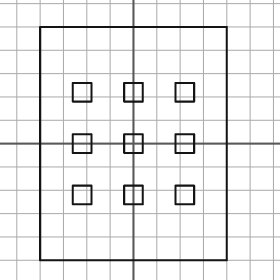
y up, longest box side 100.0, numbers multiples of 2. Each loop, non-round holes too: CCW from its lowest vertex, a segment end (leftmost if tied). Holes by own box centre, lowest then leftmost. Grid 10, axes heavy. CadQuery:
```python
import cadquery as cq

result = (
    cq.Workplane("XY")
    .moveTo(-40.0, -50.0)
    .lineTo(40.0, -50.0)
    .lineTo(40.0, 50.0)
    .lineTo(-40.0, 50.0)
    .close()
    .moveTo(-26.0, -26.0)
    .lineTo(-18.0, -26.0)
    .lineTo(-18.0, -18.0)
    .lineTo(-26.0, -18.0)
    .close()
    .moveTo(-4.0, -26.0)
    .lineTo(4.0, -26.0)
    .lineTo(4.0, -18.0)
    .lineTo(-4.0, -18.0)
    .close()
    .moveTo(18.0, -26.0)
    .lineTo(26.0, -26.0)
    .lineTo(26.0, -18.0)
    .lineTo(18.0, -18.0)
    .close()
    .moveTo(-26.0, -4.0)
    .lineTo(-18.0, -4.0)
    .lineTo(-18.0, 4.0)
    .lineTo(-26.0, 4.0)
    .close()
    .moveTo(-4.0, -4.0)
    .lineTo(4.0, -4.0)
    .lineTo(4.0, 4.0)
    .lineTo(-4.0, 4.0)
    .close()
    .moveTo(18.0, -4.0)
    .lineTo(26.0, -4.0)
    .lineTo(26.0, 4.0)
    .lineTo(18.0, 4.0)
    .close()
    .moveTo(-26.0, 18.0)
    .lineTo(-18.0, 18.0)
    .lineTo(-18.0, 26.0)
    .lineTo(-26.0, 26.0)
    .close()
    .moveTo(-4.0, 18.0)
    .lineTo(4.0, 18.0)
    .lineTo(4.0, 26.0)
    .lineTo(-4.0, 26.0)
    .close()
    .moveTo(18.0, 18.0)
    .lineTo(26.0, 18.0)
    .lineTo(26.0, 26.0)
    .lineTo(18.0, 26.0)
    .close()
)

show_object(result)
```